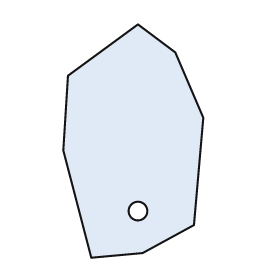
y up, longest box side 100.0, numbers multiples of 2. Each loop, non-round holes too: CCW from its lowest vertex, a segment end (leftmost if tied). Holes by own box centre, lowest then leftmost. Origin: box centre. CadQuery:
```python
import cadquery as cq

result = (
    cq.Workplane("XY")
    .moveTo(-18.0, -50.0)
    .lineTo(4.0, -48.0)
    .lineTo(26.0, -36.0)
    .lineTo(30.0, 10.0)
    .lineTo(18.0, 38.0)
    .lineTo(2.0, 50.0)
    .lineTo(-28.0, 28.0)
    .lineTo(-30.0, -4.0)
    .close()
    .moveTo(2.0, -30.0)
    .circle(4.0)
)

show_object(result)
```